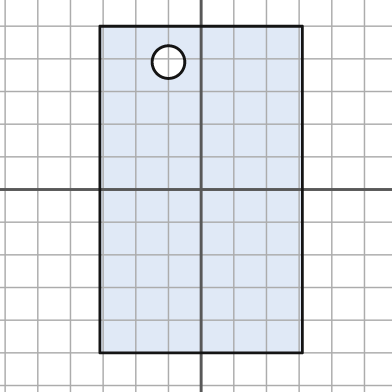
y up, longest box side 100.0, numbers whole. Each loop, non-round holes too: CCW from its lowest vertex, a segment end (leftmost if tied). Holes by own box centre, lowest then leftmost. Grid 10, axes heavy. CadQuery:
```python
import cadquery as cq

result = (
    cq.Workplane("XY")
    .moveTo(-31.0, -50.0)
    .lineTo(31.0, -50.0)
    .lineTo(31.0, 50.0)
    .lineTo(-31.0, 50.0)
    .close()
    .moveTo(-10.0, 39.0)
    .circle(5.0)
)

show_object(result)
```